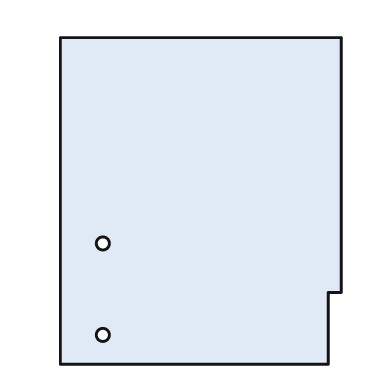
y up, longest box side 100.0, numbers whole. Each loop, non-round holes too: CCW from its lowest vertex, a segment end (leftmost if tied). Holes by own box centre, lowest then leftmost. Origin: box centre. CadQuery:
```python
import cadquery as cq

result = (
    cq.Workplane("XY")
    .moveTo(-43.0, -50.0)
    .lineTo(39.0, -50.0)
    .lineTo(39.0, -28.0)
    .lineTo(43.0, -28.0)
    .lineTo(43.0, 50.0)
    .lineTo(-43.0, 50.0)
    .close()
    .moveTo(-30.0, -41.0)
    .circle(2.0)
    .moveTo(-30.0, -13.0)
    .circle(2.0)
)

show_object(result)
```